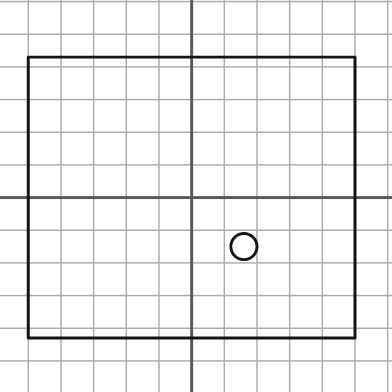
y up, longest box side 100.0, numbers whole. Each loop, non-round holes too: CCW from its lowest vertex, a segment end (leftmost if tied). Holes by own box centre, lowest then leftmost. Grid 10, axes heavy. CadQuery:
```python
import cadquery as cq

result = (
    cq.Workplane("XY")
    .moveTo(-50.0, -43.0)
    .lineTo(50.0, -43.0)
    .lineTo(50.0, 43.0)
    .lineTo(-50.0, 43.0)
    .close()
    .moveTo(16.0, -15.0)
    .circle(4.0)
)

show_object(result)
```